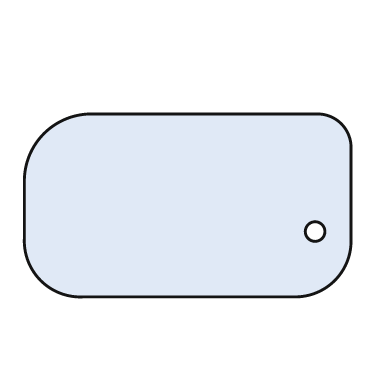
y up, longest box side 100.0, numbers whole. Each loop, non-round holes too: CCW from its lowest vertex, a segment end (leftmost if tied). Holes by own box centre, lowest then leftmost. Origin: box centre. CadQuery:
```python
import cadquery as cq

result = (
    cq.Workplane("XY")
    .moveTo(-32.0, -28.0)
    .lineTo(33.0, -28.0)
    .threePointArc((45.0, -23.0), (50.0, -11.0))
    .lineTo(50.0, 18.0)
    .threePointArc((47.0, 25.0), (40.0, 28.0))
    .lineTo(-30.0, 28.0)
    .threePointArc((-44.0, 22.0), (-50.0, 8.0))
    .lineTo(-50.0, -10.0)
    .threePointArc((-45.0, -23.0), (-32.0, -28.0))
    .close()
    .moveTo(39.0, -8.0)
    .circle(3.0)
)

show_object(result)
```